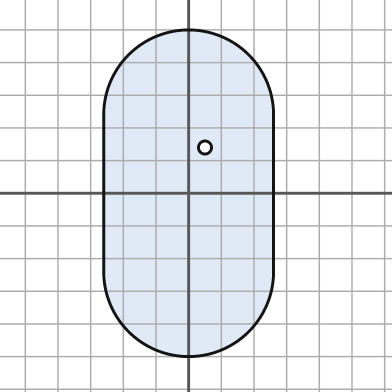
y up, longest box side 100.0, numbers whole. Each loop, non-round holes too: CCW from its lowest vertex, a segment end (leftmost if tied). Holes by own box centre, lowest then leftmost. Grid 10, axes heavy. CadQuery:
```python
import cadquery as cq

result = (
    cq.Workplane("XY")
    .moveTo(-26.0, -24.0)
    .threePointArc((0.0, -50.0), (26.0, -24.0))
    .lineTo(26.0, 24.0)
    .threePointArc((0.0, 50.0), (-26.0, 24.0))
    .close()
    .moveTo(5.0, 14.0)
    .circle(2.0)
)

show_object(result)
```